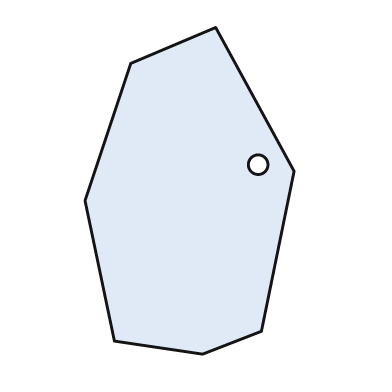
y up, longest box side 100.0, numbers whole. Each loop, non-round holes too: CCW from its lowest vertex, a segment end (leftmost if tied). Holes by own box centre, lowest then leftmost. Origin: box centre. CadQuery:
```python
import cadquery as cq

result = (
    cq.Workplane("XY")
    .moveTo(4.0, -50.0)
    .lineTo(22.0, -43.0)
    .lineTo(32.0, 6.0)
    .lineTo(8.0, 50.0)
    .lineTo(-18.0, 39.0)
    .lineTo(-32.0, -3.0)
    .lineTo(-23.0, -46.0)
    .close()
    .moveTo(21.0, 8.0)
    .circle(3.0)
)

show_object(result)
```